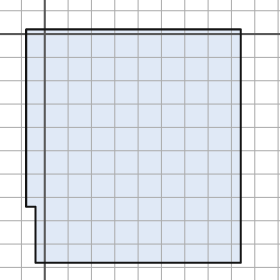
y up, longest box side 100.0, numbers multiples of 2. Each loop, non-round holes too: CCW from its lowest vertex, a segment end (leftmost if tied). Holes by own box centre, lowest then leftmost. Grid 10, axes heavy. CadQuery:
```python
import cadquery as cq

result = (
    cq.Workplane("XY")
    .moveTo(-4.0, -98.0)
    .lineTo(84.0, -98.0)
    .lineTo(84.0, 2.0)
    .lineTo(-8.0, 2.0)
    .lineTo(-8.0, -74.0)
    .lineTo(-4.0, -74.0)
    .close()
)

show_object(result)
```